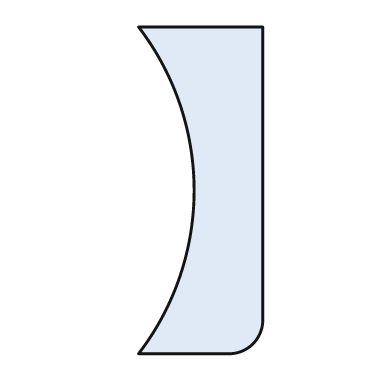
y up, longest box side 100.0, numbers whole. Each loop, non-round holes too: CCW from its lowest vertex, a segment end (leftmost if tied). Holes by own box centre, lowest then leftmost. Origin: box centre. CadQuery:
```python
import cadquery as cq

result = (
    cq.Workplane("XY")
    .moveTo(-19.0, -50.0)
    .lineTo(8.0, -50.0)
    .threePointArc((16.0, -47.0), (19.0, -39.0))
    .lineTo(19.0, 50.0)
    .lineTo(-19.0, 50.0)
    .threePointArc((-2.0, 0.0), (-19.0, -50.0))
    .close()
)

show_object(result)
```